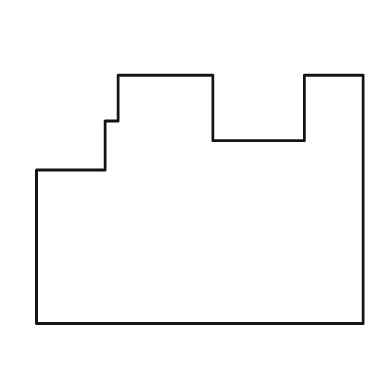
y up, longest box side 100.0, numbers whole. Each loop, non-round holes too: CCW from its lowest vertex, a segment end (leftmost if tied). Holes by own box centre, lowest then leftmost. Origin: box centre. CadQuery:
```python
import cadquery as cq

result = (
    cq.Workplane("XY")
    .moveTo(-50.0, -38.0)
    .lineTo(50.0, -38.0)
    .lineTo(50.0, 38.0)
    .lineTo(32.0, 38.0)
    .lineTo(32.0, 18.0)
    .lineTo(4.0, 18.0)
    .lineTo(4.0, 38.0)
    .lineTo(-25.0, 38.0)
    .lineTo(-25.0, 24.0)
    .lineTo(-29.0, 24.0)
    .lineTo(-29.0, 9.0)
    .lineTo(-50.0, 9.0)
    .close()
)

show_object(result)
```